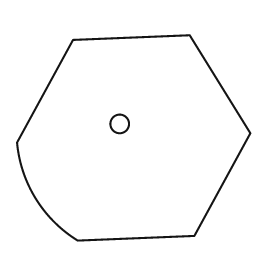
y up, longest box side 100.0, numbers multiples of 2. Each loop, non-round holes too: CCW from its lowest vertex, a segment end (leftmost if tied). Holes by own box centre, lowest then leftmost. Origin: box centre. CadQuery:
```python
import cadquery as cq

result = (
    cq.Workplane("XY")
    .moveTo(-24.0, -44.0)
    .lineTo(26.0, -42.0)
    .lineTo(50.0, 2.0)
    .lineTo(24.0, 44.0)
    .lineTo(-26.0, 42.0)
    .lineTo(-50.0, -2.0)
    .threePointArc((-42.0, -26.0), (-24.0, -44.0))
    .close()
    .moveTo(-6.0, 6.0)
    .circle(4.0)
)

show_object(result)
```